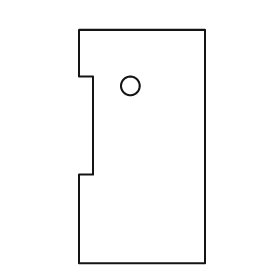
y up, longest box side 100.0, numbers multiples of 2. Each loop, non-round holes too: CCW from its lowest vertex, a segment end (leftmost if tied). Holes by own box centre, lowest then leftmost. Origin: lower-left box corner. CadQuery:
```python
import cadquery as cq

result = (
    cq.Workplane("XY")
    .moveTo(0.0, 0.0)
    .lineTo(54.0, 0.0)
    .lineTo(54.0, 100.0)
    .lineTo(0.0, 100.0)
    .lineTo(0.0, 80.0)
    .lineTo(6.0, 80.0)
    .lineTo(6.0, 38.0)
    .lineTo(0.0, 38.0)
    .close()
    .moveTo(22.0, 76.0)
    .circle(4.0)
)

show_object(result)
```